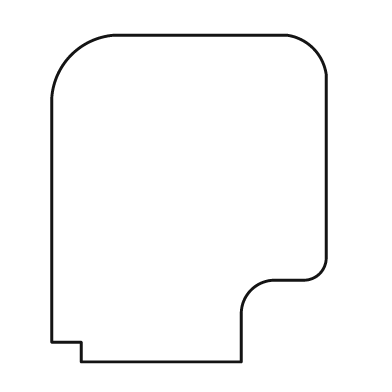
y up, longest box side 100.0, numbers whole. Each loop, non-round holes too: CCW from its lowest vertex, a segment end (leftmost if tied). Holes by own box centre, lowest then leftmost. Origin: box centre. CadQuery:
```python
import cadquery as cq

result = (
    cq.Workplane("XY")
    .moveTo(-33.0, -50.0)
    .lineTo(16.0, -50.0)
    .lineTo(16.0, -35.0)
    .threePointArc((19.0, -28.0), (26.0, -25.0))
    .lineTo(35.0, -25.0)
    .threePointArc((40.0, -23.0), (42.0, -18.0))
    .lineTo(42.0, 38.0)
    .threePointArc((38.0, 46.0), (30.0, 50.0))
    .lineTo(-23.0, 50.0)
    .threePointArc((-36.0, 44.0), (-42.0, 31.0))
    .lineTo(-42.0, -44.0)
    .lineTo(-33.0, -44.0)
    .close()
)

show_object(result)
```